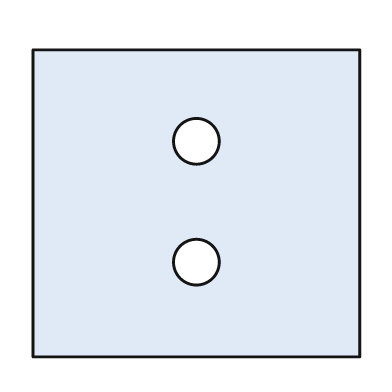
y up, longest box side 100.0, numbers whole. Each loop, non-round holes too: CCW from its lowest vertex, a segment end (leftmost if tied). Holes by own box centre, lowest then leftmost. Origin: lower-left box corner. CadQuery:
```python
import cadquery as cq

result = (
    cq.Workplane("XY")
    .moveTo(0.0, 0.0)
    .lineTo(100.0, 0.0)
    .lineTo(100.0, 94.0)
    .lineTo(0.0, 94.0)
    .close()
    .moveTo(50.0, 29.0)
    .circle(7.0)
    .moveTo(50.0, 66.0)
    .circle(7.0)
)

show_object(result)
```